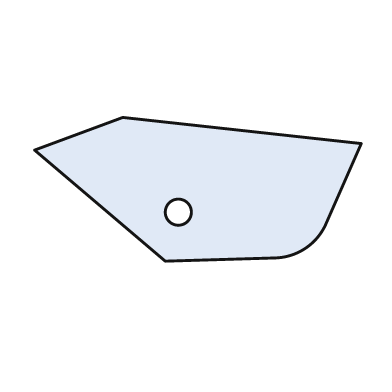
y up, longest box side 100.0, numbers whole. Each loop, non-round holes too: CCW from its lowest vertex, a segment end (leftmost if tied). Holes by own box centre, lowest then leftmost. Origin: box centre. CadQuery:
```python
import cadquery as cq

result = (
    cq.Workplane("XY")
    .moveTo(-10.0, -22.0)
    .lineTo(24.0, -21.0)
    .threePointArc((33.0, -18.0), (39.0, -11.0))
    .lineTo(50.0, 14.0)
    .lineTo(-23.0, 22.0)
    .lineTo(-50.0, 12.0)
    .close()
    .moveTo(-6.0, -7.0)
    .circle(4.0)
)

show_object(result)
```